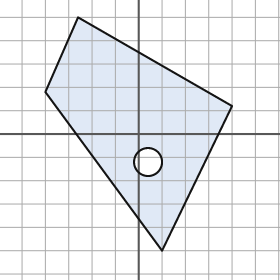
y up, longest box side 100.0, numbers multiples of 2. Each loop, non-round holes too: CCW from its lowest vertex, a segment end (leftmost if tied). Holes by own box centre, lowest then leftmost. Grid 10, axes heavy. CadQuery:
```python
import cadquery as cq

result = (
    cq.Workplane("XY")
    .moveTo(10.0, -50.0)
    .lineTo(40.0, 12.0)
    .lineTo(-26.0, 50.0)
    .lineTo(-40.0, 18.0)
    .close()
    .moveTo(4.0, -12.0)
    .circle(6.0)
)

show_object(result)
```